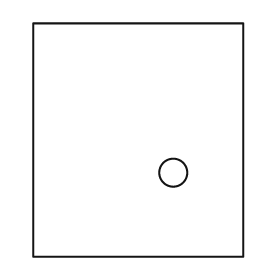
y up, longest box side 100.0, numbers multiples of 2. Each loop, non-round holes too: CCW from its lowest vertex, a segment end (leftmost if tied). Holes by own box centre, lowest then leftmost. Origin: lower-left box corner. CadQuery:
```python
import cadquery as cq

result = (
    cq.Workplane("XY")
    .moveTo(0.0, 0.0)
    .lineTo(90.0, 0.0)
    .lineTo(90.0, 100.0)
    .lineTo(0.0, 100.0)
    .close()
    .moveTo(60.0, 36.0)
    .circle(6.0)
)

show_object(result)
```